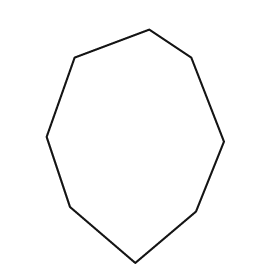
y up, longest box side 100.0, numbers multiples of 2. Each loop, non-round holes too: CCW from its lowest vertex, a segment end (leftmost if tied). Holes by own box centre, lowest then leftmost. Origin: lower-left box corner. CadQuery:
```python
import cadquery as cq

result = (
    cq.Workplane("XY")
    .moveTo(38.0, 0.0)
    .lineTo(64.0, 22.0)
    .lineTo(76.0, 52.0)
    .lineTo(62.0, 88.0)
    .lineTo(44.0, 100.0)
    .lineTo(12.0, 88.0)
    .lineTo(0.0, 54.0)
    .lineTo(10.0, 24.0)
    .close()
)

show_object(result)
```